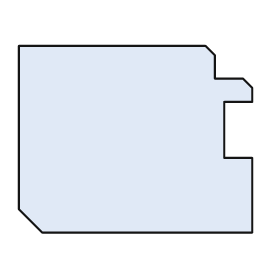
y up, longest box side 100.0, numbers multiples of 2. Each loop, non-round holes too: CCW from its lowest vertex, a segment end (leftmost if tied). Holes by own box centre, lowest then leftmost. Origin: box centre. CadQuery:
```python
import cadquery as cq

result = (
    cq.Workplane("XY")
    .moveTo(-40.0, -40.0)
    .lineTo(50.0, -40.0)
    .lineTo(50.0, -8.0)
    .lineTo(38.0, -8.0)
    .lineTo(38.0, 16.0)
    .lineTo(50.0, 16.0)
    .lineTo(50.0, 22.0)
    .lineTo(46.0, 26.0)
    .lineTo(34.0, 26.0)
    .lineTo(34.0, 36.0)
    .lineTo(30.0, 40.0)
    .lineTo(-50.0, 40.0)
    .lineTo(-50.0, -30.0)
    .close()
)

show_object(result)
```